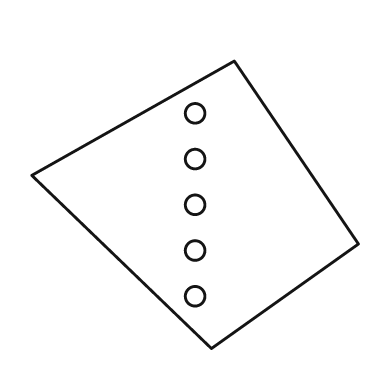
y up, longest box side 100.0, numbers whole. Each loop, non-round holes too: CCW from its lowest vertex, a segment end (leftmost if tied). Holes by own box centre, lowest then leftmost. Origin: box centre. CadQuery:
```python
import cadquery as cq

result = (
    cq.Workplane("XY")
    .moveTo(5.0, -44.0)
    .lineTo(50.0, -12.0)
    .lineTo(12.0, 44.0)
    .lineTo(-50.0, 9.0)
    .close()
    .moveTo(0.0, -28.0)
    .circle(3.0)
    .moveTo(0.0, -14.0)
    .circle(3.0)
    .moveTo(0.0, 0.0)
    .circle(3.0)
    .moveTo(0.0, 14.0)
    .circle(3.0)
    .moveTo(0.0, 28.0)
    .circle(3.0)
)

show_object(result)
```